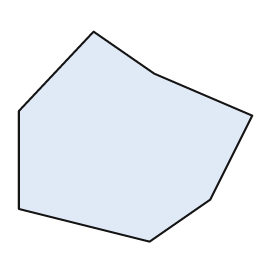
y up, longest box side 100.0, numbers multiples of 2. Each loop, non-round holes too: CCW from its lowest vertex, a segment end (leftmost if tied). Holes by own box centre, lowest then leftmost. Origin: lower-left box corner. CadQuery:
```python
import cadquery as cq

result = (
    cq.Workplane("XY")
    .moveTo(56.0, 0.0)
    .lineTo(82.0, 18.0)
    .lineTo(100.0, 54.0)
    .lineTo(58.0, 72.0)
    .lineTo(32.0, 90.0)
    .lineTo(0.0, 56.0)
    .lineTo(0.0, 14.0)
    .close()
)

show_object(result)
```